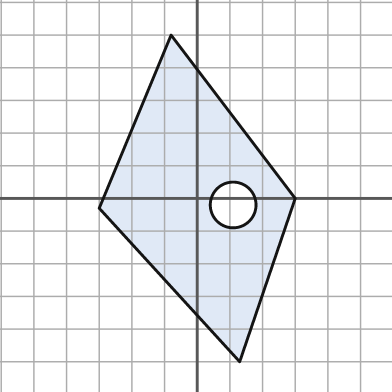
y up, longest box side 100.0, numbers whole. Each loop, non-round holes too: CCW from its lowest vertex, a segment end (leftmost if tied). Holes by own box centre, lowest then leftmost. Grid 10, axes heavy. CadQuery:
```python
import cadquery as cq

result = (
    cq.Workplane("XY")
    .moveTo(13.0, -50.0)
    .lineTo(30.0, 0.0)
    .lineTo(-8.0, 50.0)
    .lineTo(-30.0, -3.0)
    .close()
    .moveTo(11.0, -2.0)
    .circle(7.0)
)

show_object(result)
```